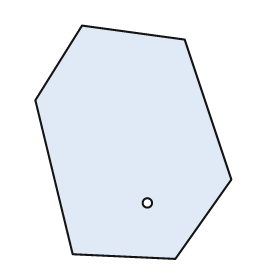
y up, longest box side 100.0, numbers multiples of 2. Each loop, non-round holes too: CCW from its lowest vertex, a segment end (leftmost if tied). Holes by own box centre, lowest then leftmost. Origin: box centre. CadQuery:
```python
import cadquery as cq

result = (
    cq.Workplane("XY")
    .moveTo(18.0, -50.0)
    .lineTo(42.0, -16.0)
    .lineTo(22.0, 44.0)
    .lineTo(-22.0, 50.0)
    .lineTo(-42.0, 18.0)
    .lineTo(-26.0, -48.0)
    .close()
    .moveTo(6.0, -26.0)
    .circle(2.0)
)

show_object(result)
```